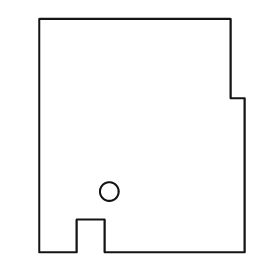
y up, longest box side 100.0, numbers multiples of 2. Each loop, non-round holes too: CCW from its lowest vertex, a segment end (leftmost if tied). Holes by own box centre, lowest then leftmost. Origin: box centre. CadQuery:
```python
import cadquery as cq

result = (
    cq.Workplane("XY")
    .moveTo(-44.0, -50.0)
    .lineTo(-28.0, -50.0)
    .lineTo(-28.0, -36.0)
    .lineTo(-16.0, -36.0)
    .lineTo(-16.0, -50.0)
    .lineTo(44.0, -50.0)
    .lineTo(44.0, 16.0)
    .lineTo(38.0, 16.0)
    .lineTo(38.0, 50.0)
    .lineTo(-44.0, 50.0)
    .close()
    .moveTo(-14.0, -24.0)
    .circle(4.0)
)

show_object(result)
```